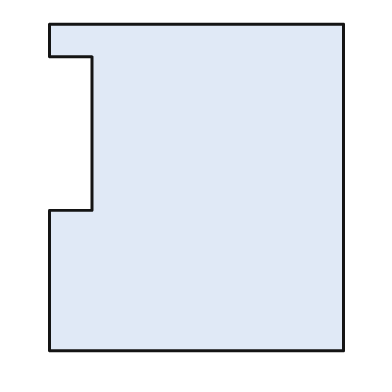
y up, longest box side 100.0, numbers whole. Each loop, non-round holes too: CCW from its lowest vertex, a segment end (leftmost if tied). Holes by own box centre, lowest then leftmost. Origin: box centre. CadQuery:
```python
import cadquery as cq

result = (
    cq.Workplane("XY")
    .moveTo(-45.0, -50.0)
    .lineTo(45.0, -50.0)
    .lineTo(45.0, 50.0)
    .lineTo(-45.0, 50.0)
    .lineTo(-45.0, 40.0)
    .lineTo(-32.0, 40.0)
    .lineTo(-32.0, -7.0)
    .lineTo(-45.0, -7.0)
    .close()
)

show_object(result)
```